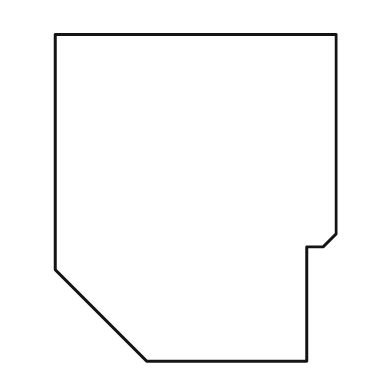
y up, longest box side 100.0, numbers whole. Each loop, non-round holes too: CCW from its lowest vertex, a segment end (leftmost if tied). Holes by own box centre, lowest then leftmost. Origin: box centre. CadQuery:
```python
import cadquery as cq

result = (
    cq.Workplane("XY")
    .moveTo(-15.0, -50.0)
    .lineTo(34.0, -50.0)
    .lineTo(34.0, -15.0)
    .lineTo(39.0, -15.0)
    .lineTo(43.0, -11.0)
    .lineTo(43.0, 50.0)
    .lineTo(-43.0, 50.0)
    .lineTo(-43.0, -22.0)
    .close()
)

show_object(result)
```